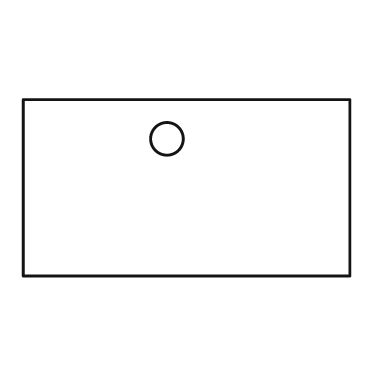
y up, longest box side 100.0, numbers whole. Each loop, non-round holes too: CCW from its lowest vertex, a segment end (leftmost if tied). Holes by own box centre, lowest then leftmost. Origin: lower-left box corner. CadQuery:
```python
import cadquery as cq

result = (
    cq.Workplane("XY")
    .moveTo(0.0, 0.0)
    .lineTo(100.0, 0.0)
    .lineTo(100.0, 54.0)
    .lineTo(0.0, 54.0)
    .close()
    .moveTo(44.0, 42.0)
    .circle(5.0)
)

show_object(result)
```